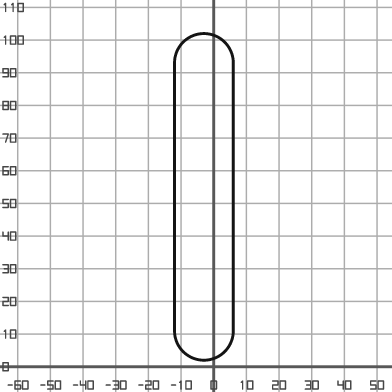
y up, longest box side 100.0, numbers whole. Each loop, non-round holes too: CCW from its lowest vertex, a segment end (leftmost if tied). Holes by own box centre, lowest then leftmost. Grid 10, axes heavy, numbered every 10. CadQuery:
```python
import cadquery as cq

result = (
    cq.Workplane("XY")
    .moveTo(-12.0, 11.0)
    .threePointArc((-3.0, 2.0), (6.0, 11.0))
    .lineTo(6.0, 93.0)
    .threePointArc((-3.0, 102.0), (-12.0, 93.0))
    .close()
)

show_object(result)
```